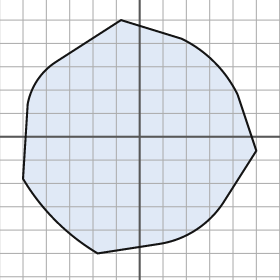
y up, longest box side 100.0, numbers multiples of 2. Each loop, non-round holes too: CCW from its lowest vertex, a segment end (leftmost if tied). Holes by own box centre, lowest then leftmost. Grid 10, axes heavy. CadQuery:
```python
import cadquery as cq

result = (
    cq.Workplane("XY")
    .moveTo(-18.0, -50.0)
    .lineTo(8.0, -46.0)
    .threePointArc((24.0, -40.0), (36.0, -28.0))
    .lineTo(50.0, -6.0)
    .lineTo(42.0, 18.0)
    .threePointArc((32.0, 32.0), (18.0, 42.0))
    .lineTo(-8.0, 50.0)
    .lineTo(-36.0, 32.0)
    .threePointArc((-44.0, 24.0), (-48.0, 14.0))
    .lineTo(-50.0, -18.0)
    .threePointArc((-36.0, -36.0), (-18.0, -50.0))
    .close()
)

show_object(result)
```